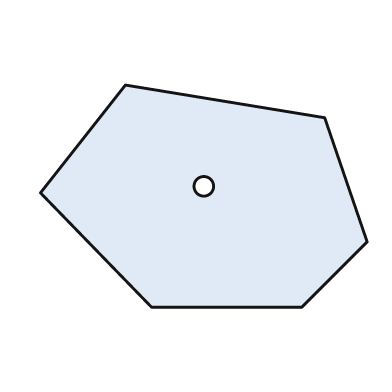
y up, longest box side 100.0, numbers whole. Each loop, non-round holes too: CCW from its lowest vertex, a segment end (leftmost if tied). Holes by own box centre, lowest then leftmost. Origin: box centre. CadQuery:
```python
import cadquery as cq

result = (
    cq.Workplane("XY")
    .moveTo(-16.0, -34.0)
    .lineTo(30.0, -34.0)
    .lineTo(50.0, -14.0)
    .lineTo(37.0, 24.0)
    .lineTo(-24.0, 34.0)
    .lineTo(-50.0, 1.0)
    .close()
    .moveTo(0.0, 3.0)
    .circle(3.0)
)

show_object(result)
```